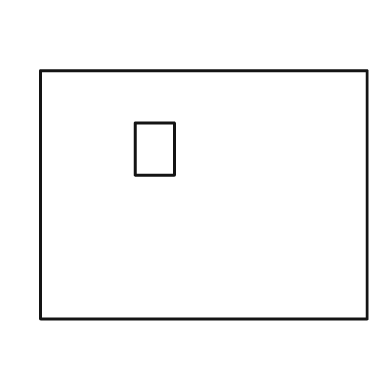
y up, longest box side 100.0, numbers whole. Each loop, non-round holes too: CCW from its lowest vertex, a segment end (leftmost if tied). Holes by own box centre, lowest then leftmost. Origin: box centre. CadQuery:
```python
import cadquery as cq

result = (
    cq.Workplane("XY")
    .moveTo(-50.0, -38.0)
    .lineTo(50.0, -38.0)
    .lineTo(50.0, 38.0)
    .lineTo(-50.0, 38.0)
    .close()
    .moveTo(-21.0, 6.0)
    .lineTo(-9.0, 6.0)
    .lineTo(-9.0, 22.0)
    .lineTo(-21.0, 22.0)
    .close()
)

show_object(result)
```